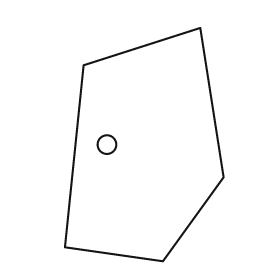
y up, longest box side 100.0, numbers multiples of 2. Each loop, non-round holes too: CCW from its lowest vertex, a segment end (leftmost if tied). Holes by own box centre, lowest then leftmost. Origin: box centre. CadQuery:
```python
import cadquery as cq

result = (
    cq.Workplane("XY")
    .moveTo(8.0, -50.0)
    .lineTo(34.0, -14.0)
    .lineTo(24.0, 50.0)
    .lineTo(-26.0, 34.0)
    .lineTo(-34.0, -44.0)
    .close()
    .moveTo(-16.0, 0.0)
    .circle(4.0)
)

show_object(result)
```